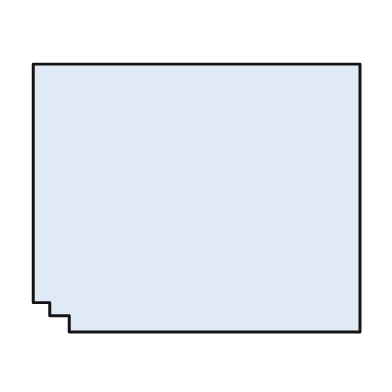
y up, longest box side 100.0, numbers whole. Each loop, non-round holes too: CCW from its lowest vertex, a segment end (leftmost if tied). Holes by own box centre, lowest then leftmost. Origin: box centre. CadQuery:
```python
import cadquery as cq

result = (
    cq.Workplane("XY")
    .moveTo(-39.0, -41.0)
    .lineTo(50.0, -41.0)
    .lineTo(50.0, 41.0)
    .lineTo(-50.0, 41.0)
    .lineTo(-50.0, -32.0)
    .lineTo(-45.0, -32.0)
    .lineTo(-45.0, -36.0)
    .lineTo(-39.0, -36.0)
    .close()
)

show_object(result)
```